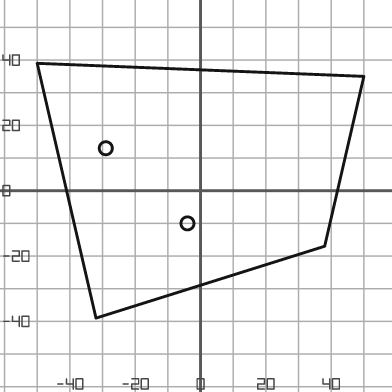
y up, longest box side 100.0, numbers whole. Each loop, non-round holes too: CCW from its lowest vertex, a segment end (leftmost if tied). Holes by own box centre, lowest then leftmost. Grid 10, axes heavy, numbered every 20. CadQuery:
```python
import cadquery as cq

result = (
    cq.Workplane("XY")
    .moveTo(-32.0, -39.0)
    .lineTo(38.0, -17.0)
    .lineTo(50.0, 35.0)
    .lineTo(-50.0, 39.0)
    .close()
    .moveTo(-4.0, -10.0)
    .circle(2.0)
    .moveTo(-29.0, 13.0)
    .circle(2.0)
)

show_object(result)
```